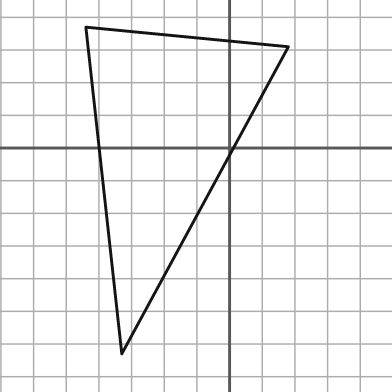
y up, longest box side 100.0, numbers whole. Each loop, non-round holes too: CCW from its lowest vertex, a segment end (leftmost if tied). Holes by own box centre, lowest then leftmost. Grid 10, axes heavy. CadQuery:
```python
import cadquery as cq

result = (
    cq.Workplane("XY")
    .moveTo(-33.0, -63.0)
    .lineTo(18.0, 31.0)
    .lineTo(-44.0, 37.0)
    .close()
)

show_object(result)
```